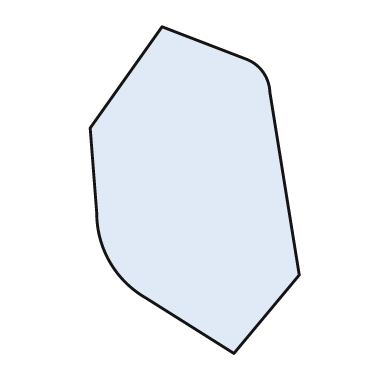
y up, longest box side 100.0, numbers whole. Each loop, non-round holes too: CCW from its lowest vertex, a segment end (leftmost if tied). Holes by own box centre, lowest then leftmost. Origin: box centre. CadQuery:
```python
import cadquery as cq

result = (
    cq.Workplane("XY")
    .moveTo(12.0, -50.0)
    .lineTo(32.0, -26.0)
    .lineTo(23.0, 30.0)
    .threePointArc((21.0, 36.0), (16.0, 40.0))
    .lineTo(-10.0, 50.0)
    .lineTo(-32.0, 19.0)
    .lineTo(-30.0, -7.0)
    .threePointArc((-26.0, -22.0), (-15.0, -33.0))
    .close()
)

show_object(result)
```